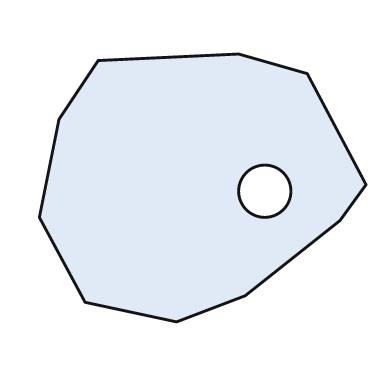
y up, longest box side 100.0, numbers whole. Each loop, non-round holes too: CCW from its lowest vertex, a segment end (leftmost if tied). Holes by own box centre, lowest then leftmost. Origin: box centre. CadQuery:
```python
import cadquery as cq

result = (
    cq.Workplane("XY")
    .moveTo(-8.0, -41.0)
    .lineTo(13.0, -33.0)
    .lineTo(42.0, -10.0)
    .lineTo(50.0, 1.0)
    .lineTo(32.0, 35.0)
    .lineTo(11.0, 41.0)
    .lineTo(-32.0, 39.0)
    .lineTo(-44.0, 21.0)
    .lineTo(-50.0, -9.0)
    .lineTo(-36.0, -35.0)
    .close()
    .moveTo(19.0, -1.0)
    .circle(8.0)
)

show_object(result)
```